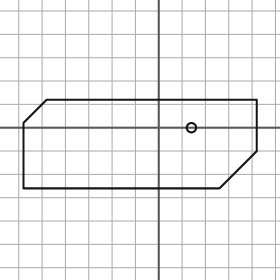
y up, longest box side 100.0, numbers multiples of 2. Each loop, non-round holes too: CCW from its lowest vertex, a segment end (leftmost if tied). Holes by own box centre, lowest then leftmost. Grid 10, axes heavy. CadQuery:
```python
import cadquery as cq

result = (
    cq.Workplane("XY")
    .moveTo(-58.0, -26.0)
    .lineTo(26.0, -26.0)
    .lineTo(42.0, -10.0)
    .lineTo(42.0, 12.0)
    .lineTo(-48.0, 12.0)
    .lineTo(-58.0, 2.0)
    .close()
    .moveTo(14.0, 0.0)
    .circle(2.0)
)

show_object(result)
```